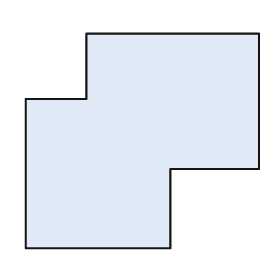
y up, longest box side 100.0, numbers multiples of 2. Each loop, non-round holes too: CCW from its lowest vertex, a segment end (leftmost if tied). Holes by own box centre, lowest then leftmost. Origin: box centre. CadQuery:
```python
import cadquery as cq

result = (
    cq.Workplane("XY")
    .moveTo(-50.0, -46.0)
    .lineTo(12.0, -46.0)
    .lineTo(12.0, -12.0)
    .lineTo(50.0, -12.0)
    .lineTo(50.0, 46.0)
    .lineTo(-24.0, 46.0)
    .lineTo(-24.0, 18.0)
    .lineTo(-50.0, 18.0)
    .close()
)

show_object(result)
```